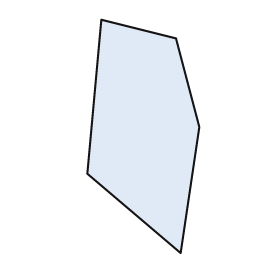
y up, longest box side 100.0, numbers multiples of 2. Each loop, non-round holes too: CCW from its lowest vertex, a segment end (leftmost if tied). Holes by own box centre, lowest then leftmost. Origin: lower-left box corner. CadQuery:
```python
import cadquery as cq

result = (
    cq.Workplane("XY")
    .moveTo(40.0, 0.0)
    .lineTo(48.0, 54.0)
    .lineTo(38.0, 92.0)
    .lineTo(6.0, 100.0)
    .lineTo(0.0, 34.0)
    .close()
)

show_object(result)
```